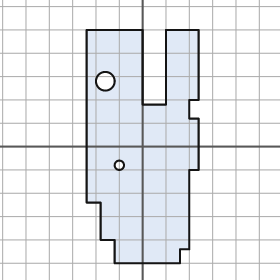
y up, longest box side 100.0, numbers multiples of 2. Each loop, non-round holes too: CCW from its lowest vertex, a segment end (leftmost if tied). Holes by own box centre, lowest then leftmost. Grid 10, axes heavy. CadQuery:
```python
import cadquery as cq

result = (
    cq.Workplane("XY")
    .moveTo(-12.0, -50.0)
    .lineTo(16.0, -50.0)
    .lineTo(16.0, -44.0)
    .lineTo(20.0, -44.0)
    .lineTo(20.0, -10.0)
    .lineTo(24.0, -10.0)
    .lineTo(24.0, 12.0)
    .lineTo(20.0, 12.0)
    .lineTo(20.0, 20.0)
    .lineTo(24.0, 20.0)
    .lineTo(24.0, 50.0)
    .lineTo(10.0, 50.0)
    .lineTo(10.0, 18.0)
    .lineTo(0.0, 18.0)
    .lineTo(0.0, 50.0)
    .lineTo(-24.0, 50.0)
    .lineTo(-24.0, -24.0)
    .lineTo(-18.0, -24.0)
    .lineTo(-18.0, -40.0)
    .lineTo(-12.0, -40.0)
    .close()
    .moveTo(-10.0, -8.0)
    .circle(2.0)
    .moveTo(-16.0, 28.0)
    .circle(4.0)
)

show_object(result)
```